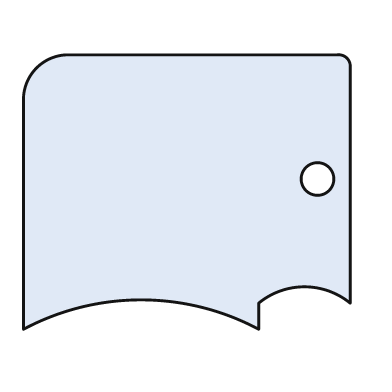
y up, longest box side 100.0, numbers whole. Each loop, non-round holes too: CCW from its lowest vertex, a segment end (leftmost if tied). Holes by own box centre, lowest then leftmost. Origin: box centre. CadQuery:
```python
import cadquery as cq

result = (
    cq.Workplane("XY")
    .moveTo(-50.0, -42.0)
    .threePointArc((-14.0, -33.0), (22.0, -42.0))
    .lineTo(22.0, -34.0)
    .threePointArc((36.0, -29.0), (50.0, -34.0))
    .lineTo(50.0, 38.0)
    .threePointArc((49.0, 41.0), (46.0, 42.0))
    .lineTo(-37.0, 42.0)
    .threePointArc((-46.0, 38.0), (-50.0, 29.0))
    .close()
    .moveTo(40.0, 4.0)
    .circle(5.0)
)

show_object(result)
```